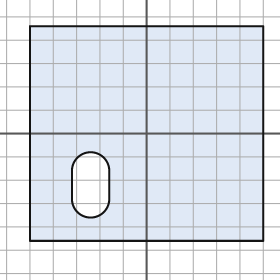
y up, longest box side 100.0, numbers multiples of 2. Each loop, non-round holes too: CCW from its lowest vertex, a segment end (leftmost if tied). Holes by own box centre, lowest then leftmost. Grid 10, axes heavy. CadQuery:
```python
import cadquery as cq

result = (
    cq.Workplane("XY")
    .moveTo(-50.0, -46.0)
    .lineTo(50.0, -46.0)
    .lineTo(50.0, 46.0)
    .lineTo(-50.0, 46.0)
    .close()
    .moveTo(-32.0, -28.0)
    .threePointArc((-24.0, -36.0), (-16.0, -28.0))
    .lineTo(-16.0, -16.0)
    .threePointArc((-24.0, -8.0), (-32.0, -16.0))
    .close()
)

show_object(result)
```